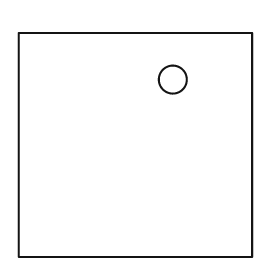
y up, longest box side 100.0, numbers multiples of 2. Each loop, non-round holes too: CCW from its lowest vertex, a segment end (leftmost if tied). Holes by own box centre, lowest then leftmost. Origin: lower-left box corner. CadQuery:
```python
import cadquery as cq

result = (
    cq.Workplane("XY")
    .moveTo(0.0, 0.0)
    .lineTo(100.0, 0.0)
    .lineTo(100.0, 96.0)
    .lineTo(0.0, 96.0)
    .close()
    .moveTo(66.0, 76.0)
    .circle(6.0)
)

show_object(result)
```